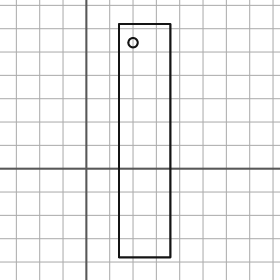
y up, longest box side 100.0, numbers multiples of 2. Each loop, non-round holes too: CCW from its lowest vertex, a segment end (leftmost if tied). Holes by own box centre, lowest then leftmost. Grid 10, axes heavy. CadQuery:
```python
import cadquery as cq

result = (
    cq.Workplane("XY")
    .moveTo(14.0, -38.0)
    .lineTo(36.0, -38.0)
    .lineTo(36.0, 62.0)
    .lineTo(14.0, 62.0)
    .close()
    .moveTo(20.0, 54.0)
    .circle(2.0)
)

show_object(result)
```